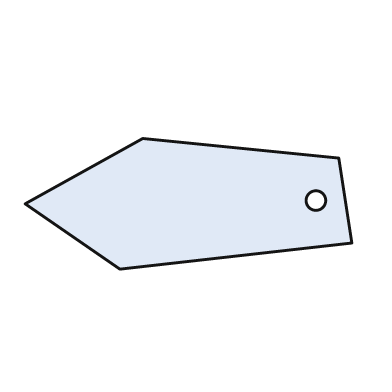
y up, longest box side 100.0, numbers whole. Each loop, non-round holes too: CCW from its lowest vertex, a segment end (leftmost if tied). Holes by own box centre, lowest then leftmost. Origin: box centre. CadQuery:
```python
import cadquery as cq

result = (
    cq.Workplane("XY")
    .moveTo(-21.0, -20.0)
    .lineTo(50.0, -12.0)
    .lineTo(46.0, 14.0)
    .lineTo(-14.0, 20.0)
    .lineTo(-50.0, 0.0)
    .close()
    .moveTo(39.0, 1.0)
    .circle(3.0)
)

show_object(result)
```